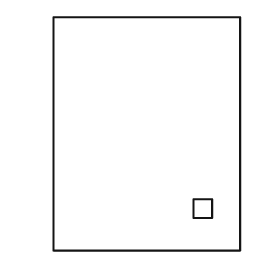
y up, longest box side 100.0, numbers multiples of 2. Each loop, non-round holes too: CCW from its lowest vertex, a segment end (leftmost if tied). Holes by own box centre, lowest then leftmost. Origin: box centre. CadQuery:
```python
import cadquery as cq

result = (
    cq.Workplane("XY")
    .moveTo(-40.0, -50.0)
    .lineTo(40.0, -50.0)
    .lineTo(40.0, 50.0)
    .lineTo(-40.0, 50.0)
    .close()
    .moveTo(20.0, -36.0)
    .lineTo(28.0, -36.0)
    .lineTo(28.0, -28.0)
    .lineTo(20.0, -28.0)
    .close()
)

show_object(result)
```